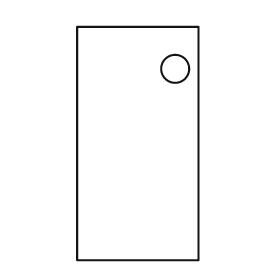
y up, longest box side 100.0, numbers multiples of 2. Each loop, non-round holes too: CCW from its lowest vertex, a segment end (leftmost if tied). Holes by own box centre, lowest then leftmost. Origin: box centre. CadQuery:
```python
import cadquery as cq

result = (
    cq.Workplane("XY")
    .moveTo(-26.0, -50.0)
    .lineTo(26.0, -50.0)
    .lineTo(26.0, 50.0)
    .lineTo(-26.0, 50.0)
    .close()
    .moveTo(16.0, 32.0)
    .circle(6.0)
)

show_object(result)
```